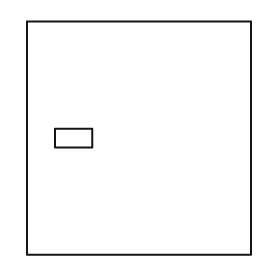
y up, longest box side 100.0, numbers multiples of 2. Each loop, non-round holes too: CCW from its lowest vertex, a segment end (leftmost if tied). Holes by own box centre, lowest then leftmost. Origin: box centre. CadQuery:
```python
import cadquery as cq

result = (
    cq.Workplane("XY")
    .moveTo(-48.0, -50.0)
    .lineTo(48.0, -50.0)
    .lineTo(48.0, 50.0)
    .lineTo(-48.0, 50.0)
    .close()
    .moveTo(-36.0, -4.0)
    .lineTo(-20.0, -4.0)
    .lineTo(-20.0, 4.0)
    .lineTo(-36.0, 4.0)
    .close()
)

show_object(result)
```